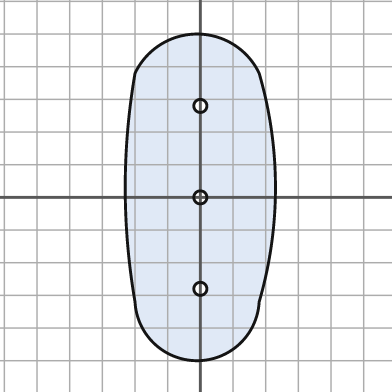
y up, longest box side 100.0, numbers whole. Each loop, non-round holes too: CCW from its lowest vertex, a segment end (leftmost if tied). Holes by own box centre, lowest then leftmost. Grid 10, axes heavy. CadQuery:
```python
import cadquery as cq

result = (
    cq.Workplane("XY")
    .moveTo(-20.0, -32.0)
    .threePointArc((-1.0, -50.0), (18.0, -32.0))
    .threePointArc((23.0, 3.0), (18.0, 38.0))
    .threePointArc((-1.0, 50.0), (-20.0, 38.0))
    .threePointArc((-23.0, 3.0), (-20.0, -32.0))
    .close()
    .moveTo(0.0, -28.0)
    .circle(2.0)
    .moveTo(0.0, 0.0)
    .circle(2.0)
    .moveTo(0.0, 28.0)
    .circle(2.0)
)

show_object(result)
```